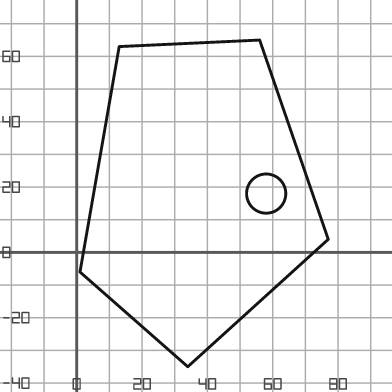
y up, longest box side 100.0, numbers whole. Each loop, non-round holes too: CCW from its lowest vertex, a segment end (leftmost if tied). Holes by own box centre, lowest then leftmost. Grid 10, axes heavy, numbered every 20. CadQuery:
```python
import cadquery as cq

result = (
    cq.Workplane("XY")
    .moveTo(34.0, -35.0)
    .lineTo(77.0, 4.0)
    .lineTo(56.0, 65.0)
    .lineTo(13.0, 63.0)
    .lineTo(1.0, -6.0)
    .close()
    .moveTo(58.0, 18.0)
    .circle(6.0)
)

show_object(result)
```